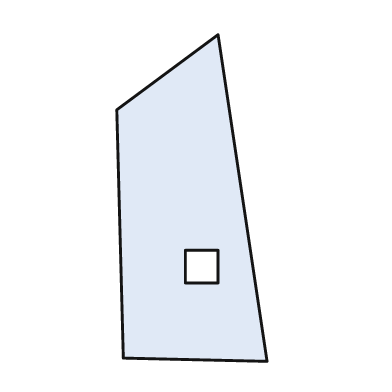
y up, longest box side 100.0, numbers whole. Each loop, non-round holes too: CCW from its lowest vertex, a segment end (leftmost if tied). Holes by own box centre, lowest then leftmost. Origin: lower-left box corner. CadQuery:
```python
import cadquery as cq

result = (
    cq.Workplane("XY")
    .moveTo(46.0, 0.0)
    .lineTo(31.0, 100.0)
    .lineTo(0.0, 77.0)
    .lineTo(2.0, 1.0)
    .close()
    .moveTo(21.0, 24.0)
    .lineTo(31.0, 24.0)
    .lineTo(31.0, 34.0)
    .lineTo(21.0, 34.0)
    .close()
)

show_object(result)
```